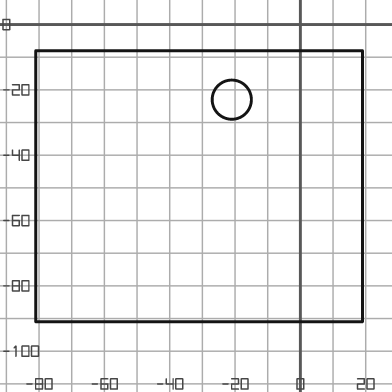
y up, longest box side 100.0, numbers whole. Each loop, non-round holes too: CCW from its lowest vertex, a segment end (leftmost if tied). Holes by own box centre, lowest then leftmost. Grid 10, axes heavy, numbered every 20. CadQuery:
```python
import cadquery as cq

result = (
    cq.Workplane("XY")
    .moveTo(-81.0, -91.0)
    .lineTo(19.0, -91.0)
    .lineTo(19.0, -8.0)
    .lineTo(-81.0, -8.0)
    .close()
    .moveTo(-21.0, -23.0)
    .circle(6.0)
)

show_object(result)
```